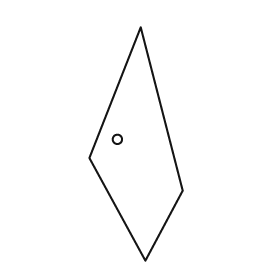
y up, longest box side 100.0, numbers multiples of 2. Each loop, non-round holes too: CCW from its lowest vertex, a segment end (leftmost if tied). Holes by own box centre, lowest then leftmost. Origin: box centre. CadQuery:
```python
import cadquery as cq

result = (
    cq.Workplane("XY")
    .moveTo(4.0, -50.0)
    .lineTo(20.0, -20.0)
    .lineTo(2.0, 50.0)
    .lineTo(-20.0, -6.0)
    .close()
    .moveTo(-8.0, 2.0)
    .circle(2.0)
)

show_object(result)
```